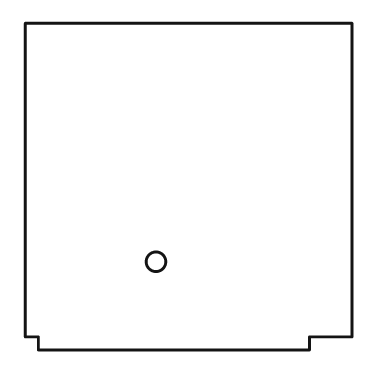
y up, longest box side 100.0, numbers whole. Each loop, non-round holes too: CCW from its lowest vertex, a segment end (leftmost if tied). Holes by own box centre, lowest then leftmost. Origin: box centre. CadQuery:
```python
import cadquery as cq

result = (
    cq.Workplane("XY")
    .moveTo(-46.0, -50.0)
    .lineTo(37.0, -50.0)
    .lineTo(37.0, -46.0)
    .lineTo(50.0, -46.0)
    .lineTo(50.0, 50.0)
    .lineTo(-50.0, 50.0)
    .lineTo(-50.0, -46.0)
    .lineTo(-46.0, -46.0)
    .close()
    .moveTo(-10.0, -23.0)
    .circle(3.0)
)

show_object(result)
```